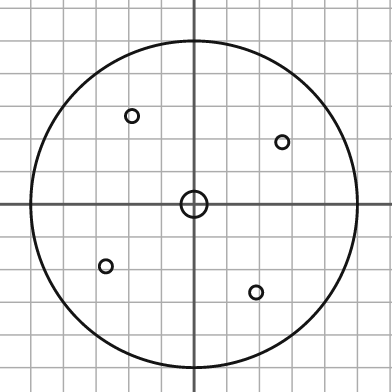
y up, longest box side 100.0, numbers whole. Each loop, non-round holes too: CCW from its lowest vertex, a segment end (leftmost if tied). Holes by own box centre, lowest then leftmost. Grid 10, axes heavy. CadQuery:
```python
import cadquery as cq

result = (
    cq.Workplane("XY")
    .moveTo(0.0, 0.0)
    .circle(50.0)
    .moveTo(19.0, -27.0)
    .circle(2.0)
    .moveTo(-27.0, -19.0)
    .circle(2.0)
    .moveTo(0.0, 0.0)
    .circle(4.0)
    .moveTo(27.0, 19.0)
    .circle(2.0)
    .moveTo(-19.0, 27.0)
    .circle(2.0)
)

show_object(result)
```